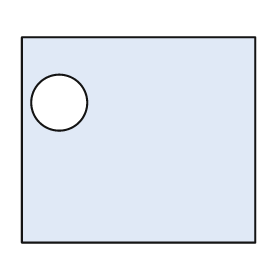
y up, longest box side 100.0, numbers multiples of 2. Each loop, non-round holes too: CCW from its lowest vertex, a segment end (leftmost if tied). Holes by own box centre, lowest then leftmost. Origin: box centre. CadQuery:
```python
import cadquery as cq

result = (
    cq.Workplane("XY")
    .moveTo(-50.0, -44.0)
    .lineTo(50.0, -44.0)
    .lineTo(50.0, 44.0)
    .lineTo(-50.0, 44.0)
    .close()
    .moveTo(-34.0, 16.0)
    .circle(12.0)
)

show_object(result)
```